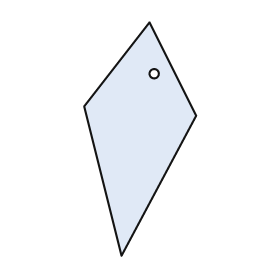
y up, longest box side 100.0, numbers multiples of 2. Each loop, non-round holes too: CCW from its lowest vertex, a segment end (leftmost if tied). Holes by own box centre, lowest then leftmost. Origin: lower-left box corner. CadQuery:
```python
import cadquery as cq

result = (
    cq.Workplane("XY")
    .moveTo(16.0, 0.0)
    .lineTo(48.0, 60.0)
    .lineTo(28.0, 100.0)
    .lineTo(0.0, 64.0)
    .close()
    .moveTo(30.0, 78.0)
    .circle(2.0)
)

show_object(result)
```